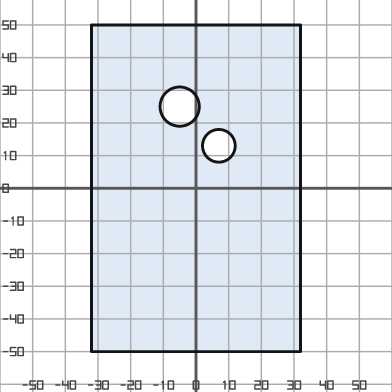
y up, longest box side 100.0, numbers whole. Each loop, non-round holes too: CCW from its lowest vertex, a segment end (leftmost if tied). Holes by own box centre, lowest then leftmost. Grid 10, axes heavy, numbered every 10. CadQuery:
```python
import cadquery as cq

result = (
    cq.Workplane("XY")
    .moveTo(-32.0, -50.0)
    .lineTo(32.0, -50.0)
    .lineTo(32.0, 50.0)
    .lineTo(-32.0, 50.0)
    .close()
    .moveTo(7.0, 13.0)
    .circle(5.0)
    .moveTo(-5.0, 25.0)
    .circle(6.0)
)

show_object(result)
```